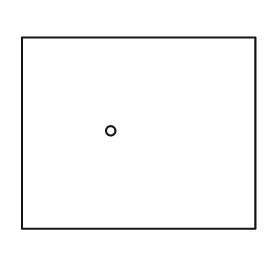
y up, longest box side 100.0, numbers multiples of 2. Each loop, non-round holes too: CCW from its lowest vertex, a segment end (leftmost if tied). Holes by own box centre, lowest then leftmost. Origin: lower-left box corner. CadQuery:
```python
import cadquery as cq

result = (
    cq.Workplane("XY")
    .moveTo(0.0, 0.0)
    .lineTo(100.0, 0.0)
    .lineTo(100.0, 82.0)
    .lineTo(0.0, 82.0)
    .close()
    .moveTo(38.0, 42.0)
    .circle(2.0)
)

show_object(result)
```